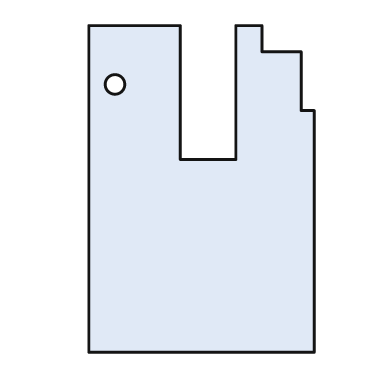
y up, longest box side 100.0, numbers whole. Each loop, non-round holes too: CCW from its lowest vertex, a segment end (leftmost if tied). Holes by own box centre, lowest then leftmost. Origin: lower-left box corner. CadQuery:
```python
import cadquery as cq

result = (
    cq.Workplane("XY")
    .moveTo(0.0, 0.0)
    .lineTo(69.0, 0.0)
    .lineTo(69.0, 74.0)
    .lineTo(65.0, 74.0)
    .lineTo(65.0, 92.0)
    .lineTo(53.0, 92.0)
    .lineTo(53.0, 100.0)
    .lineTo(45.0, 100.0)
    .lineTo(45.0, 59.0)
    .lineTo(28.0, 59.0)
    .lineTo(28.0, 100.0)
    .lineTo(0.0, 100.0)
    .close()
    .moveTo(8.0, 82.0)
    .circle(3.0)
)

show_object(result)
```